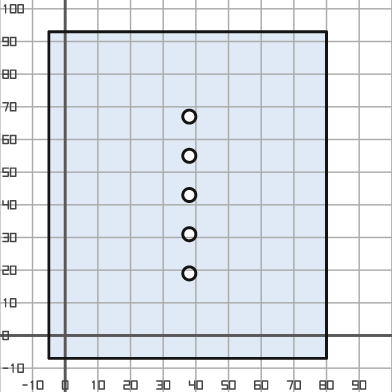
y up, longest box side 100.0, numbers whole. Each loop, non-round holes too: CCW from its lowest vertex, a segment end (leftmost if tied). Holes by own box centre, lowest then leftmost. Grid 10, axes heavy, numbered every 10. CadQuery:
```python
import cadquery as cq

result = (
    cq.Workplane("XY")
    .moveTo(-5.0, -7.0)
    .lineTo(80.0, -7.0)
    .lineTo(80.0, 93.0)
    .lineTo(-5.0, 93.0)
    .close()
    .moveTo(38.0, 19.0)
    .circle(2.0)
    .moveTo(38.0, 31.0)
    .circle(2.0)
    .moveTo(38.0, 43.0)
    .circle(2.0)
    .moveTo(38.0, 55.0)
    .circle(2.0)
    .moveTo(38.0, 67.0)
    .circle(2.0)
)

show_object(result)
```